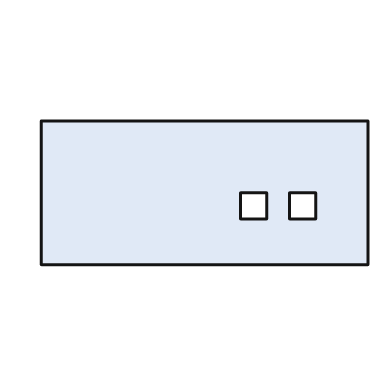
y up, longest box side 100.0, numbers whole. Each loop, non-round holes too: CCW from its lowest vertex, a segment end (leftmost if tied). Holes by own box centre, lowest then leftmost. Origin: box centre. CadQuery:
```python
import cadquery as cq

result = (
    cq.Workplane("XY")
    .moveTo(-50.0, -22.0)
    .lineTo(50.0, -22.0)
    .lineTo(50.0, 22.0)
    .lineTo(-50.0, 22.0)
    .close()
    .moveTo(11.0, -8.0)
    .lineTo(19.0, -8.0)
    .lineTo(19.0, 0.0)
    .lineTo(11.0, 0.0)
    .close()
    .moveTo(26.0, -8.0)
    .lineTo(34.0, -8.0)
    .lineTo(34.0, 0.0)
    .lineTo(26.0, 0.0)
    .close()
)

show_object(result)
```